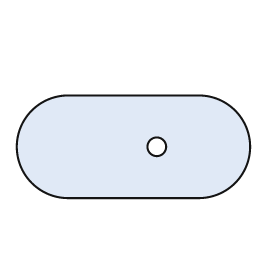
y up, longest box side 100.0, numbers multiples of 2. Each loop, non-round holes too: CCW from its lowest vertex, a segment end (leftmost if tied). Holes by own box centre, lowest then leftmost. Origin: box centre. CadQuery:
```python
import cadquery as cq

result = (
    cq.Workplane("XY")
    .moveTo(-28.0, -22.0)
    .lineTo(28.0, -22.0)
    .threePointArc((50.0, 0.0), (28.0, 22.0))
    .lineTo(-28.0, 22.0)
    .threePointArc((-50.0, 0.0), (-28.0, -22.0))
    .close()
    .moveTo(10.0, 0.0)
    .circle(4.0)
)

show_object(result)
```